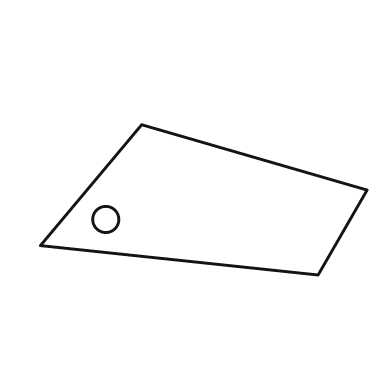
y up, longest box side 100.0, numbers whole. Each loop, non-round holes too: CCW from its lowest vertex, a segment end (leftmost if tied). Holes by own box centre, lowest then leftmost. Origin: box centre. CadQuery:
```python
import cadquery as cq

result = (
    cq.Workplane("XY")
    .moveTo(35.0, -23.0)
    .lineTo(50.0, 3.0)
    .lineTo(-19.0, 23.0)
    .lineTo(-50.0, -14.0)
    .close()
    .moveTo(-30.0, -6.0)
    .circle(4.0)
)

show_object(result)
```